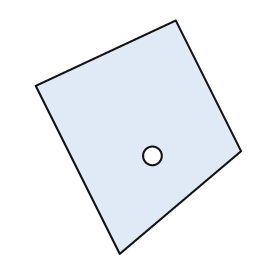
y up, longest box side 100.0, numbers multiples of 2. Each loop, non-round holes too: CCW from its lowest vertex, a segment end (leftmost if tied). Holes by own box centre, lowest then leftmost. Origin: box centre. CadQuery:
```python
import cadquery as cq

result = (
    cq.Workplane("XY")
    .moveTo(-8.0, -50.0)
    .lineTo(44.0, -6.0)
    .lineTo(16.0, 50.0)
    .lineTo(-44.0, 22.0)
    .close()
    .moveTo(6.0, -8.0)
    .circle(4.0)
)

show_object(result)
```